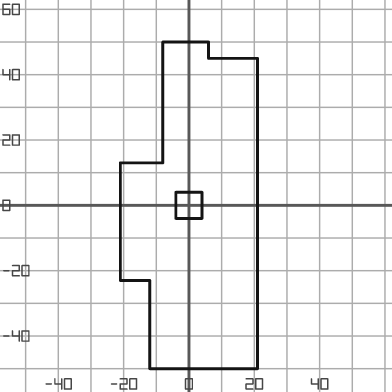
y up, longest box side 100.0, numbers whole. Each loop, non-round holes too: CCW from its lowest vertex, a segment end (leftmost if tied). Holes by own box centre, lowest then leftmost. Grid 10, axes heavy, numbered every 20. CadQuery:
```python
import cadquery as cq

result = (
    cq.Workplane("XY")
    .moveTo(-12.0, -50.0)
    .lineTo(21.0, -50.0)
    .lineTo(21.0, 45.0)
    .lineTo(6.0, 45.0)
    .lineTo(6.0, 50.0)
    .lineTo(-8.0, 50.0)
    .lineTo(-8.0, 13.0)
    .lineTo(-21.0, 13.0)
    .lineTo(-21.0, -23.0)
    .lineTo(-12.0, -23.0)
    .close()
    .moveTo(-4.0, -4.0)
    .lineTo(4.0, -4.0)
    .lineTo(4.0, 4.0)
    .lineTo(-4.0, 4.0)
    .close()
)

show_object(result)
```